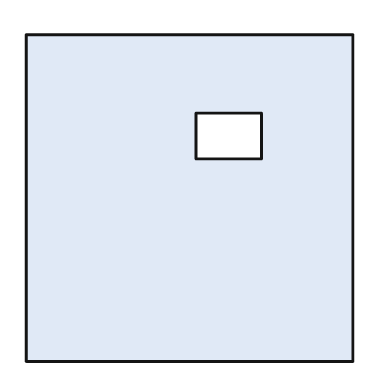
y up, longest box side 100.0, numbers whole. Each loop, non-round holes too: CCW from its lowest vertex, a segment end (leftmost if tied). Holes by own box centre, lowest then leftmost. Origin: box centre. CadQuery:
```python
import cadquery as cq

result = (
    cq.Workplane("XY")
    .moveTo(-50.0, -50.0)
    .lineTo(50.0, -50.0)
    .lineTo(50.0, 50.0)
    .lineTo(-50.0, 50.0)
    .close()
    .moveTo(2.0, 12.0)
    .lineTo(22.0, 12.0)
    .lineTo(22.0, 26.0)
    .lineTo(2.0, 26.0)
    .close()
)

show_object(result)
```